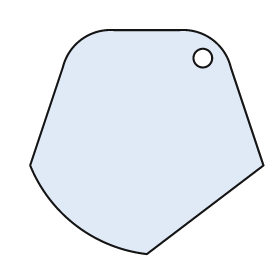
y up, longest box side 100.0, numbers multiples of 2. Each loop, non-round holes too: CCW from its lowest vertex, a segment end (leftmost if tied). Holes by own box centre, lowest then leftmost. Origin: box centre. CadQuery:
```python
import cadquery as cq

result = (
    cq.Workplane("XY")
    .moveTo(0.0, -48.0)
    .lineTo(50.0, -10.0)
    .lineTo(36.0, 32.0)
    .threePointArc((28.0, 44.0), (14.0, 48.0))
    .lineTo(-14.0, 48.0)
    .threePointArc((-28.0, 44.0), (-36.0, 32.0))
    .lineTo(-50.0, -10.0)
    .threePointArc((-30.0, -36.0), (0.0, -48.0))
    .close()
    .moveTo(24.0, 36.0)
    .circle(4.0)
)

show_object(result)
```